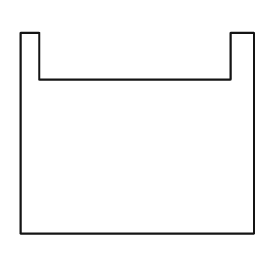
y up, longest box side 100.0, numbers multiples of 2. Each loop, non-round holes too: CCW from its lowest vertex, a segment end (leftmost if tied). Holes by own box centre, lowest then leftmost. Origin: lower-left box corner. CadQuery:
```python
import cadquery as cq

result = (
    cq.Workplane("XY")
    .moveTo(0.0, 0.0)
    .lineTo(100.0, 0.0)
    .lineTo(100.0, 86.0)
    .lineTo(90.0, 86.0)
    .lineTo(90.0, 66.0)
    .lineTo(8.0, 66.0)
    .lineTo(8.0, 86.0)
    .lineTo(0.0, 86.0)
    .close()
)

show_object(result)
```